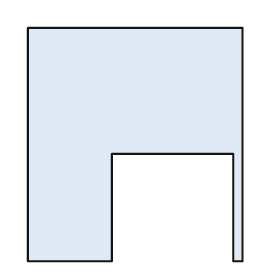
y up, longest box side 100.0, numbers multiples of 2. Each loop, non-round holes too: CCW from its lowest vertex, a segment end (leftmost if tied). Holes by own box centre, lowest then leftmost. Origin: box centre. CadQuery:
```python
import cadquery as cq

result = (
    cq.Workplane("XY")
    .moveTo(-46.0, -50.0)
    .lineTo(-10.0, -50.0)
    .lineTo(-10.0, -4.0)
    .lineTo(42.0, -4.0)
    .lineTo(42.0, -50.0)
    .lineTo(46.0, -50.0)
    .lineTo(46.0, 50.0)
    .lineTo(-46.0, 50.0)
    .close()
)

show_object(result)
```